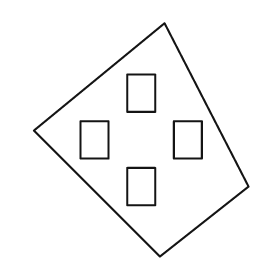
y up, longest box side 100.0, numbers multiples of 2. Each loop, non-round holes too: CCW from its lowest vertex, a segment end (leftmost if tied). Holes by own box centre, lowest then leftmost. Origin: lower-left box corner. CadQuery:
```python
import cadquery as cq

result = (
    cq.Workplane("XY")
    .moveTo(54.0, 0.0)
    .lineTo(92.0, 30.0)
    .lineTo(56.0, 100.0)
    .lineTo(0.0, 54.0)
    .close()
    .moveTo(40.0, 22.0)
    .lineTo(52.0, 22.0)
    .lineTo(52.0, 38.0)
    .lineTo(40.0, 38.0)
    .close()
    .moveTo(20.0, 42.0)
    .lineTo(32.0, 42.0)
    .lineTo(32.0, 58.0)
    .lineTo(20.0, 58.0)
    .close()
    .moveTo(60.0, 42.0)
    .lineTo(72.0, 42.0)
    .lineTo(72.0, 58.0)
    .lineTo(60.0, 58.0)
    .close()
    .moveTo(40.0, 62.0)
    .lineTo(52.0, 62.0)
    .lineTo(52.0, 78.0)
    .lineTo(40.0, 78.0)
    .close()
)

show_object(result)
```